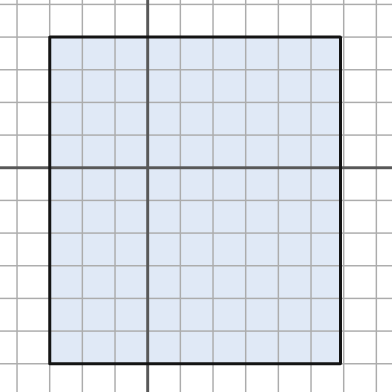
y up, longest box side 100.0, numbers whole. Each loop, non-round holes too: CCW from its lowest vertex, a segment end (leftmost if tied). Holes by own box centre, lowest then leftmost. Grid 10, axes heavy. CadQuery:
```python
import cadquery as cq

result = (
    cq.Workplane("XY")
    .moveTo(-30.0, -60.0)
    .lineTo(59.0, -60.0)
    .lineTo(59.0, 40.0)
    .lineTo(-30.0, 40.0)
    .close()
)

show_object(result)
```